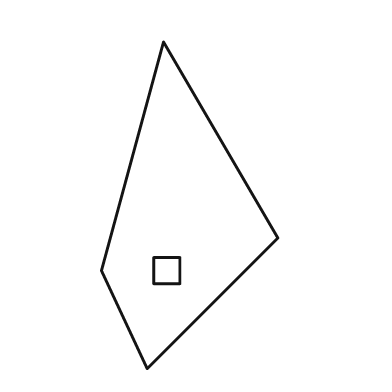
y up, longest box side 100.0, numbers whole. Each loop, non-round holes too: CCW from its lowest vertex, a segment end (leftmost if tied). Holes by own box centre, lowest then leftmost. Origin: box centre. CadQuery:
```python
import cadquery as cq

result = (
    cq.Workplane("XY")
    .moveTo(-13.0, -50.0)
    .lineTo(27.0, -10.0)
    .lineTo(-8.0, 50.0)
    .lineTo(-27.0, -20.0)
    .close()
    .moveTo(-11.0, -24.0)
    .lineTo(-3.0, -24.0)
    .lineTo(-3.0, -16.0)
    .lineTo(-11.0, -16.0)
    .close()
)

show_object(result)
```